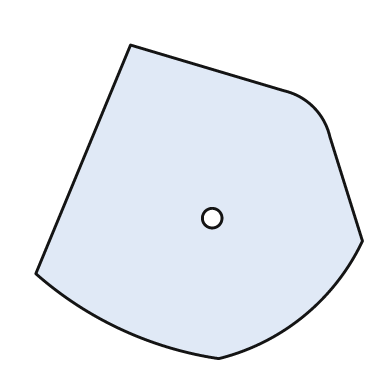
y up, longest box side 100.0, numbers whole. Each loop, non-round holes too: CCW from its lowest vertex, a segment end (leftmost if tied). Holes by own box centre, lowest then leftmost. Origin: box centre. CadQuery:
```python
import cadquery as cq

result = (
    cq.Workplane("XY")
    .moveTo(6.0, -48.0)
    .threePointArc((32.0, -35.0), (50.0, -12.0))
    .lineTo(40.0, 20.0)
    .threePointArc((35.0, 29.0), (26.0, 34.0))
    .lineTo(-21.0, 48.0)
    .lineTo(-50.0, -22.0)
    .threePointArc((-24.0, -39.0), (6.0, -48.0))
    .close()
    .moveTo(4.0, -5.0)
    .circle(3.0)
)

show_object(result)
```